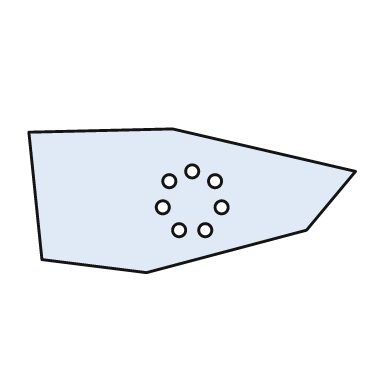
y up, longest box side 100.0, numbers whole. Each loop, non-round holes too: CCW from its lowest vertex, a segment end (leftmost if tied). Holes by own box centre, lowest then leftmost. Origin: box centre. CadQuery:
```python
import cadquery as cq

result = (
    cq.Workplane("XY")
    .moveTo(-14.0, -22.0)
    .lineTo(35.0, -9.0)
    .lineTo(50.0, 9.0)
    .lineTo(-6.0, 22.0)
    .lineTo(-50.0, 21.0)
    .lineTo(-46.0, -18.0)
    .close()
    .moveTo(-4.0, -9.0)
    .circle(2.0)
    .moveTo(4.0, -9.0)
    .circle(2.0)
    .moveTo(-9.0, -2.0)
    .circle(2.0)
    .moveTo(9.0, -2.0)
    .circle(2.0)
    .moveTo(-7.0, 6.0)
    .circle(2.0)
    .moveTo(7.0, 6.0)
    .circle(2.0)
    .moveTo(0.0, 9.0)
    .circle(2.0)
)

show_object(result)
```